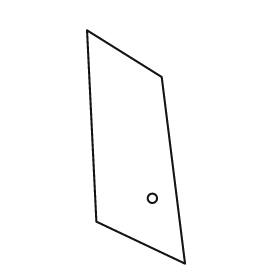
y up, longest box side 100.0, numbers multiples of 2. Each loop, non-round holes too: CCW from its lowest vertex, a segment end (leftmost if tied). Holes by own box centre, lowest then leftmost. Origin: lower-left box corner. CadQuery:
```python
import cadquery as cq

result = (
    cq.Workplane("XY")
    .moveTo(42.0, 0.0)
    .lineTo(32.0, 80.0)
    .lineTo(0.0, 100.0)
    .lineTo(4.0, 18.0)
    .close()
    .moveTo(28.0, 28.0)
    .circle(2.0)
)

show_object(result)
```